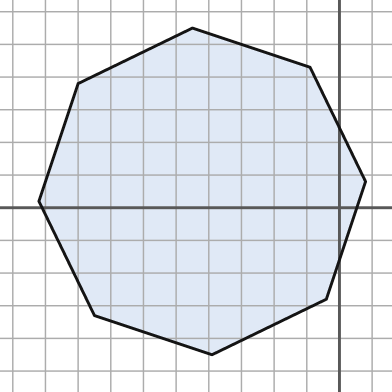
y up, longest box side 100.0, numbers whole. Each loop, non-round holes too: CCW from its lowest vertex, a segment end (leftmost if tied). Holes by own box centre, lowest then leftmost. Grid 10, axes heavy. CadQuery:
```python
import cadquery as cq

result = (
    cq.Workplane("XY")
    .moveTo(-39.0, -45.0)
    .lineTo(-4.0, -28.0)
    .lineTo(8.0, 8.0)
    .lineTo(-9.0, 43.0)
    .lineTo(-45.0, 55.0)
    .lineTo(-80.0, 38.0)
    .lineTo(-92.0, 2.0)
    .lineTo(-75.0, -33.0)
    .close()
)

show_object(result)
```